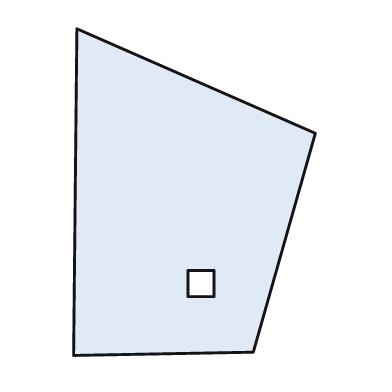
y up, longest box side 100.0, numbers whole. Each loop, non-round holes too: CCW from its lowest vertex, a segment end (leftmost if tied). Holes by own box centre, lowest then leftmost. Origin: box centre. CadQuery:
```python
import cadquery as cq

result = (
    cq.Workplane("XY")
    .moveTo(-37.0, -50.0)
    .lineTo(18.0, -49.0)
    .lineTo(37.0, 18.0)
    .lineTo(-36.0, 50.0)
    .close()
    .moveTo(-2.0, -32.0)
    .lineTo(6.0, -32.0)
    .lineTo(6.0, -24.0)
    .lineTo(-2.0, -24.0)
    .close()
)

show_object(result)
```